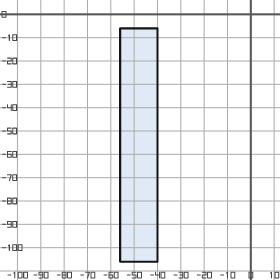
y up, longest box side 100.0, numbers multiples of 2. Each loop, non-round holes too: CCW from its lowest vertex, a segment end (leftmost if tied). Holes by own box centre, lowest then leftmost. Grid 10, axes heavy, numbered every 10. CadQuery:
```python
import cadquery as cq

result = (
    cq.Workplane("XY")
    .moveTo(-56.0, -106.0)
    .lineTo(-40.0, -106.0)
    .lineTo(-40.0, -6.0)
    .lineTo(-56.0, -6.0)
    .close()
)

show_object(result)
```